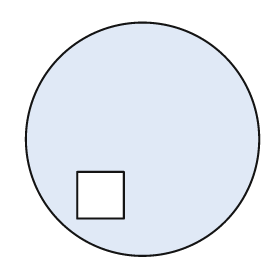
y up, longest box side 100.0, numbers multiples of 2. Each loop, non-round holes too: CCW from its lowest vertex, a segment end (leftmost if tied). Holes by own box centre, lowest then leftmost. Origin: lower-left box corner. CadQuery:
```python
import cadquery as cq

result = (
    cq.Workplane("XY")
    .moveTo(50.0, 50.0)
    .circle(50.0)
    .moveTo(22.0, 16.0)
    .lineTo(42.0, 16.0)
    .lineTo(42.0, 36.0)
    .lineTo(22.0, 36.0)
    .close()
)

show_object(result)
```